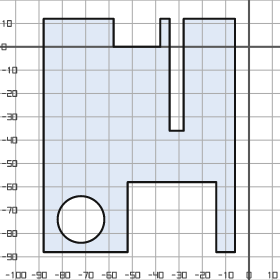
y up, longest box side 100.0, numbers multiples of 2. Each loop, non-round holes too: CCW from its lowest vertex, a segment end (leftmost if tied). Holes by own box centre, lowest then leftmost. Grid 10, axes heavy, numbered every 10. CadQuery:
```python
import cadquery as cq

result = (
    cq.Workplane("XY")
    .moveTo(-88.0, -88.0)
    .lineTo(-52.0, -88.0)
    .lineTo(-52.0, -58.0)
    .lineTo(-14.0, -58.0)
    .lineTo(-14.0, -88.0)
    .lineTo(-6.0, -88.0)
    .lineTo(-6.0, 12.0)
    .lineTo(-28.0, 12.0)
    .lineTo(-28.0, -36.0)
    .lineTo(-34.0, -36.0)
    .lineTo(-34.0, 12.0)
    .lineTo(-38.0, 12.0)
    .lineTo(-38.0, 0.0)
    .lineTo(-58.0, 0.0)
    .lineTo(-58.0, 12.0)
    .lineTo(-88.0, 12.0)
    .close()
    .moveTo(-72.0, -74.0)
    .circle(10.0)
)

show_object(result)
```